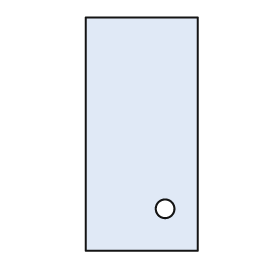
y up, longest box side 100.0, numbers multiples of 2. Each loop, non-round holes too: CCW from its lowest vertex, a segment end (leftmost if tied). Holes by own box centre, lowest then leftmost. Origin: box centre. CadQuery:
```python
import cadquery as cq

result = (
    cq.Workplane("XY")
    .moveTo(-24.0, -50.0)
    .lineTo(24.0, -50.0)
    .lineTo(24.0, 50.0)
    .lineTo(-24.0, 50.0)
    .close()
    .moveTo(10.0, -32.0)
    .circle(4.0)
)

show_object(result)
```